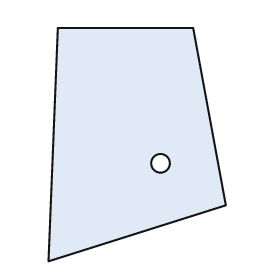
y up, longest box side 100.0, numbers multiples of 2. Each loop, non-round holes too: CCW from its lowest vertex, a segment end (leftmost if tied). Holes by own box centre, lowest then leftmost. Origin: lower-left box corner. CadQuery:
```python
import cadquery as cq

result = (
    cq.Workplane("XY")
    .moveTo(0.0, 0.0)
    .lineTo(76.0, 24.0)
    .lineTo(62.0, 100.0)
    .lineTo(4.0, 100.0)
    .close()
    .moveTo(48.0, 42.0)
    .circle(4.0)
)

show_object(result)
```